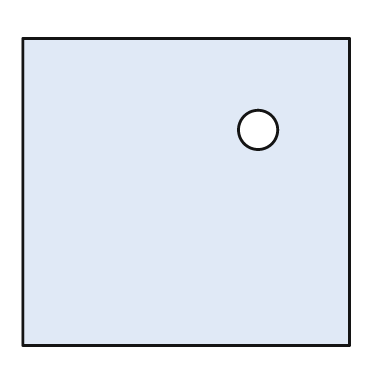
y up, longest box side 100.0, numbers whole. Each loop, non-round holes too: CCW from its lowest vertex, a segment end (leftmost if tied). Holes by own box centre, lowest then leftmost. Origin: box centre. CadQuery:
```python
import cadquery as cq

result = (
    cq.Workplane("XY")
    .moveTo(-50.0, -47.0)
    .lineTo(50.0, -47.0)
    .lineTo(50.0, 47.0)
    .lineTo(-50.0, 47.0)
    .close()
    .moveTo(22.0, 19.0)
    .circle(6.0)
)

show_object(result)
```